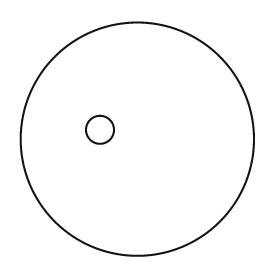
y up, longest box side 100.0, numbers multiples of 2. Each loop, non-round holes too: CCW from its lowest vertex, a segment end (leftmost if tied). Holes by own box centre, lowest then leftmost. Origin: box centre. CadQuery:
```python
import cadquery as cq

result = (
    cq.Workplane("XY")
    .moveTo(0.0, 0.0)
    .circle(50.0)
    .moveTo(-16.0, 4.0)
    .circle(6.0)
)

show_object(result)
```